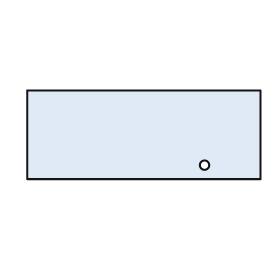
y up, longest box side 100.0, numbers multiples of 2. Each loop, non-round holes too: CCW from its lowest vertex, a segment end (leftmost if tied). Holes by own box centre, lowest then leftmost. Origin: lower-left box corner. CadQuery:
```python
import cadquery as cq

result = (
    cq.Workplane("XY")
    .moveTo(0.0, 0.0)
    .lineTo(100.0, 0.0)
    .lineTo(100.0, 38.0)
    .lineTo(0.0, 38.0)
    .close()
    .moveTo(76.0, 6.0)
    .circle(2.0)
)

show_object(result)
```